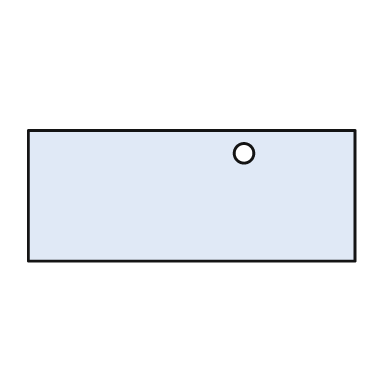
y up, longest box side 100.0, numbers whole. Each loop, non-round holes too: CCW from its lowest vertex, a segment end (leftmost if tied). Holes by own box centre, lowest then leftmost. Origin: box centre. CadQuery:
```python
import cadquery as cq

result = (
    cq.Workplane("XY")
    .moveTo(-50.0, -20.0)
    .lineTo(50.0, -20.0)
    .lineTo(50.0, 20.0)
    .lineTo(-50.0, 20.0)
    .close()
    .moveTo(16.0, 13.0)
    .circle(3.0)
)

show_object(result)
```